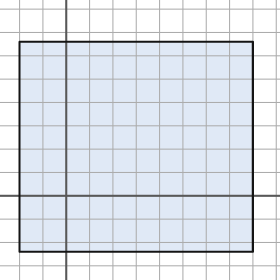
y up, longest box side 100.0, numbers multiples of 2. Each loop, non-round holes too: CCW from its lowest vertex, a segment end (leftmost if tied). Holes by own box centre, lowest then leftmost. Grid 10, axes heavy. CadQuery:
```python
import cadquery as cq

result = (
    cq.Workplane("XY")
    .moveTo(-20.0, -24.0)
    .lineTo(80.0, -24.0)
    .lineTo(80.0, 66.0)
    .lineTo(-20.0, 66.0)
    .close()
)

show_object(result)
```